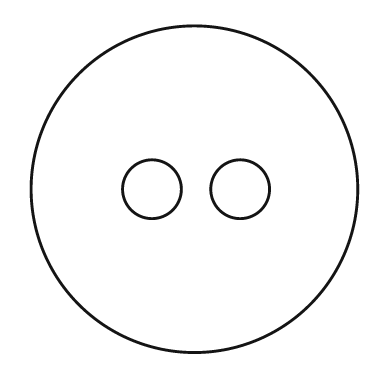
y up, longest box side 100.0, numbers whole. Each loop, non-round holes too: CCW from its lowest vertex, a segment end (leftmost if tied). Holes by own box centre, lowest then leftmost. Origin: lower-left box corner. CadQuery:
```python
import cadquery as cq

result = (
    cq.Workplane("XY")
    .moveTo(50.0, 50.0)
    .circle(50.0)
    .moveTo(37.0, 50.0)
    .circle(9.0)
    .moveTo(64.0, 50.0)
    .circle(9.0)
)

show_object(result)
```